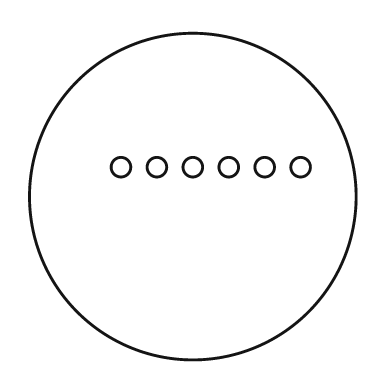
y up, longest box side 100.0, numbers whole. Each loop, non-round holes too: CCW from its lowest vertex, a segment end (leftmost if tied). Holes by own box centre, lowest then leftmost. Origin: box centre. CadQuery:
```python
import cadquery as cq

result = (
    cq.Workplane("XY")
    .moveTo(0.0, 0.0)
    .circle(50.0)
    .moveTo(-22.0, 9.0)
    .circle(3.0)
    .moveTo(-11.0, 9.0)
    .circle(3.0)
    .moveTo(0.0, 9.0)
    .circle(3.0)
    .moveTo(11.0, 9.0)
    .circle(3.0)
    .moveTo(22.0, 9.0)
    .circle(3.0)
    .moveTo(33.0, 9.0)
    .circle(3.0)
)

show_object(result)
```